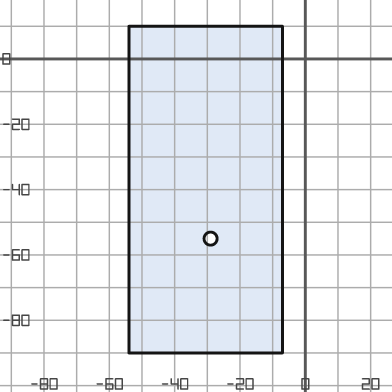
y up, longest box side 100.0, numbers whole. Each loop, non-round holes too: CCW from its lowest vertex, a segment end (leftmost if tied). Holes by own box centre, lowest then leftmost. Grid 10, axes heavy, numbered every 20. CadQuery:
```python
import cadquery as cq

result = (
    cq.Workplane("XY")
    .moveTo(-54.0, -90.0)
    .lineTo(-7.0, -90.0)
    .lineTo(-7.0, 10.0)
    .lineTo(-54.0, 10.0)
    .close()
    .moveTo(-29.0, -55.0)
    .circle(2.0)
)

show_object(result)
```